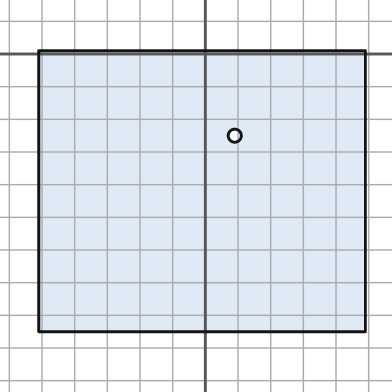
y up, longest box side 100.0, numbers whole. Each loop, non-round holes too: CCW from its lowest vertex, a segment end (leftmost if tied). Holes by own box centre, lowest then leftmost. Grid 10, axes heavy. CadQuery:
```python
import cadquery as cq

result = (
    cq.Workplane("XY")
    .moveTo(-51.0, -85.0)
    .lineTo(49.0, -85.0)
    .lineTo(49.0, 1.0)
    .lineTo(-51.0, 1.0)
    .close()
    .moveTo(9.0, -25.0)
    .circle(2.0)
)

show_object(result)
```